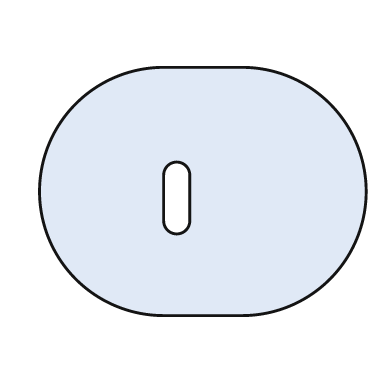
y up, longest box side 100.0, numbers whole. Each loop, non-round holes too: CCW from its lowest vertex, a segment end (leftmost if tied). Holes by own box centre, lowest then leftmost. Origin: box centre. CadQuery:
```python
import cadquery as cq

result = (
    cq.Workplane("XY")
    .moveTo(-12.0, -38.0)
    .lineTo(12.0, -38.0)
    .threePointArc((50.0, 0.0), (12.0, 38.0))
    .lineTo(-12.0, 38.0)
    .threePointArc((-50.0, 0.0), (-12.0, -38.0))
    .close()
    .moveTo(-12.0, -9.0)
    .threePointArc((-8.0, -13.0), (-4.0, -9.0))
    .lineTo(-4.0, 5.0)
    .threePointArc((-8.0, 9.0), (-12.0, 5.0))
    .close()
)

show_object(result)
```